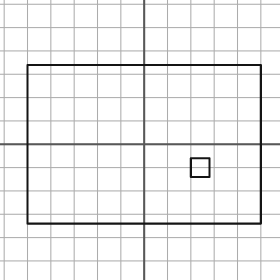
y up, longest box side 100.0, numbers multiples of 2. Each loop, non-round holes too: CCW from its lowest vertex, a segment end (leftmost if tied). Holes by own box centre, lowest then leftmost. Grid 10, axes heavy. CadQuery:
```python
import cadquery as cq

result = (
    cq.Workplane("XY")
    .moveTo(-50.0, -34.0)
    .lineTo(50.0, -34.0)
    .lineTo(50.0, 34.0)
    .lineTo(-50.0, 34.0)
    .close()
    .moveTo(20.0, -14.0)
    .lineTo(28.0, -14.0)
    .lineTo(28.0, -6.0)
    .lineTo(20.0, -6.0)
    .close()
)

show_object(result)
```